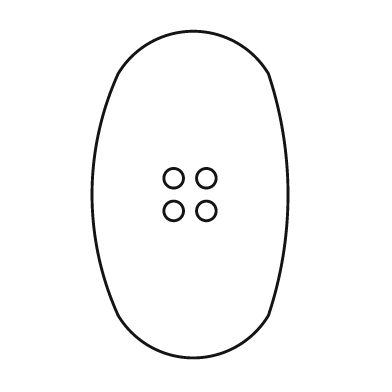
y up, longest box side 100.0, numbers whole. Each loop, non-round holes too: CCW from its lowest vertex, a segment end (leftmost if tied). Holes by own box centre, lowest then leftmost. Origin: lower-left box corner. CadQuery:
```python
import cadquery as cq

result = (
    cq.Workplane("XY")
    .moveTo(8.0, 13.0)
    .threePointArc((31.0, 0.0), (54.0, 13.0))
    .threePointArc((60.0, 50.0), (54.0, 87.0))
    .threePointArc((31.0, 100.0), (8.0, 87.0))
    .threePointArc((0.0, 50.0), (8.0, 13.0))
    .close()
    .moveTo(25.0, 45.0)
    .circle(3.0)
    .moveTo(35.0, 45.0)
    .circle(3.0)
    .moveTo(25.0, 55.0)
    .circle(3.0)
    .moveTo(35.0, 55.0)
    .circle(3.0)
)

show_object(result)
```